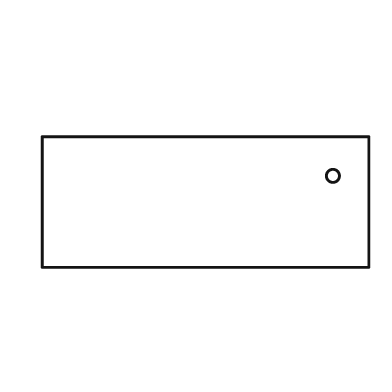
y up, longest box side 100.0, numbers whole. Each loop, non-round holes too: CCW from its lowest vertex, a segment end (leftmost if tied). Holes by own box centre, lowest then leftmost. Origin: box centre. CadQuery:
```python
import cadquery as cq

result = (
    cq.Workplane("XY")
    .moveTo(-50.0, -20.0)
    .lineTo(50.0, -20.0)
    .lineTo(50.0, 20.0)
    .lineTo(-50.0, 20.0)
    .close()
    .moveTo(39.0, 8.0)
    .circle(2.0)
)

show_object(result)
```